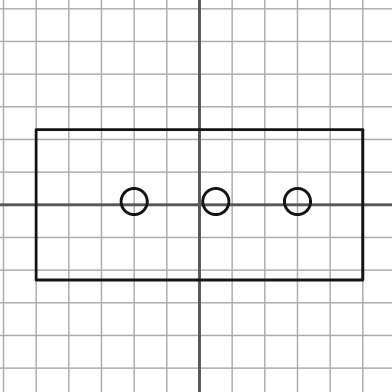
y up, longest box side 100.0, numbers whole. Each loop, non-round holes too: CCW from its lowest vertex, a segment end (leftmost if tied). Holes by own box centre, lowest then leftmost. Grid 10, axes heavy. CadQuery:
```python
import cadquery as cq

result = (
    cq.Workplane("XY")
    .moveTo(-50.0, -23.0)
    .lineTo(50.0, -23.0)
    .lineTo(50.0, 23.0)
    .lineTo(-50.0, 23.0)
    .close()
    .moveTo(-20.0, 1.0)
    .circle(4.0)
    .moveTo(5.0, 1.0)
    .circle(4.0)
    .moveTo(30.0, 1.0)
    .circle(4.0)
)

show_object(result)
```